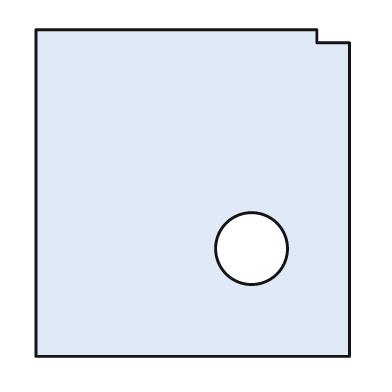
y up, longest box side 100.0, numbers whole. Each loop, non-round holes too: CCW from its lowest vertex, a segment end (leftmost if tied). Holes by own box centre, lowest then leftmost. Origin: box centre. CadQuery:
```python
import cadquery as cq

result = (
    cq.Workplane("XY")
    .moveTo(-48.0, -50.0)
    .lineTo(48.0, -50.0)
    .lineTo(48.0, 46.0)
    .lineTo(38.0, 46.0)
    .lineTo(38.0, 50.0)
    .lineTo(-48.0, 50.0)
    .close()
    .moveTo(18.0, -17.0)
    .circle(11.0)
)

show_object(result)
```